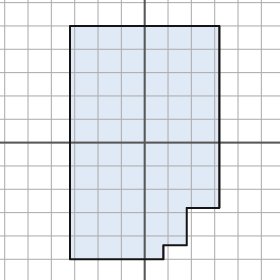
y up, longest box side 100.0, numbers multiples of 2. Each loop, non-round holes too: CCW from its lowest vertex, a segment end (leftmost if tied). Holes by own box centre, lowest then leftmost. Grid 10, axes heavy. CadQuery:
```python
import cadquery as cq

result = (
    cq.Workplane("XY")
    .moveTo(-32.0, -50.0)
    .lineTo(8.0, -50.0)
    .lineTo(8.0, -44.0)
    .lineTo(18.0, -44.0)
    .lineTo(18.0, -28.0)
    .lineTo(32.0, -28.0)
    .lineTo(32.0, 50.0)
    .lineTo(-32.0, 50.0)
    .close()
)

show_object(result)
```